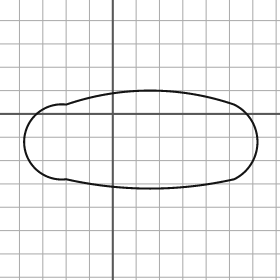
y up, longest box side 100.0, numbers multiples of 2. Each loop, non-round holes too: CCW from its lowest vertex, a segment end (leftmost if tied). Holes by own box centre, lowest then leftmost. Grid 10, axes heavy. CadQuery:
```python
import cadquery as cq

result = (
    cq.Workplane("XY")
    .moveTo(-20.0, -28.0)
    .threePointArc((16.0, -32.0), (52.0, -28.0))
    .threePointArc((62.0, -12.0), (52.0, 4.0))
    .threePointArc((16.0, 10.0), (-20.0, 4.0))
    .threePointArc((-38.0, -12.0), (-20.0, -28.0))
    .close()
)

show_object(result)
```